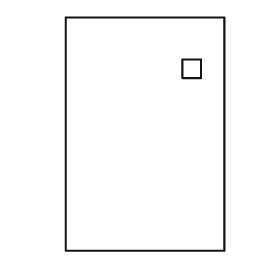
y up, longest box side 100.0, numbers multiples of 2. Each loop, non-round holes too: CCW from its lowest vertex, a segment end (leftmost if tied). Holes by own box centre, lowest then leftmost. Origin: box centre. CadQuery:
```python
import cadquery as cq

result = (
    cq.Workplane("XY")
    .moveTo(-34.0, -50.0)
    .lineTo(34.0, -50.0)
    .lineTo(34.0, 50.0)
    .lineTo(-34.0, 50.0)
    .close()
    .moveTo(16.0, 24.0)
    .lineTo(24.0, 24.0)
    .lineTo(24.0, 32.0)
    .lineTo(16.0, 32.0)
    .close()
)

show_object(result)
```